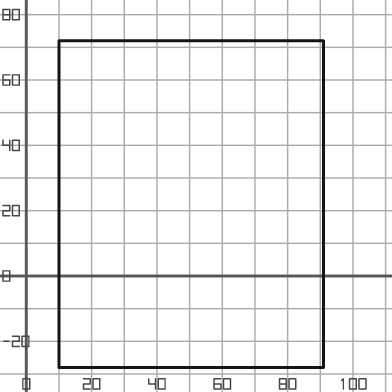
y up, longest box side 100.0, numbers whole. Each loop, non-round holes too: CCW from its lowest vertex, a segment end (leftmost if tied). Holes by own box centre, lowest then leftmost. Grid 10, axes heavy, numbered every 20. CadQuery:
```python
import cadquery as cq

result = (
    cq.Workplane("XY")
    .moveTo(10.0, -28.0)
    .lineTo(91.0, -28.0)
    .lineTo(91.0, 72.0)
    .lineTo(10.0, 72.0)
    .close()
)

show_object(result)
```